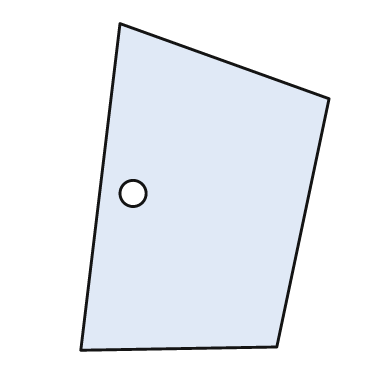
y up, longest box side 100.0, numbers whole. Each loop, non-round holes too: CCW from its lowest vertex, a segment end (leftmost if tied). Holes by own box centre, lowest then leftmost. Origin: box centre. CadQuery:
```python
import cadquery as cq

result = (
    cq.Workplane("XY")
    .moveTo(-38.0, -50.0)
    .lineTo(22.0, -49.0)
    .lineTo(38.0, 27.0)
    .lineTo(-26.0, 50.0)
    .close()
    .moveTo(-22.0, -2.0)
    .circle(4.0)
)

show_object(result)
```